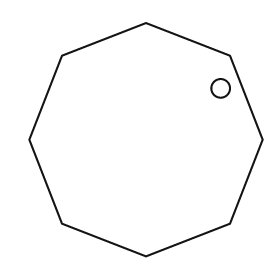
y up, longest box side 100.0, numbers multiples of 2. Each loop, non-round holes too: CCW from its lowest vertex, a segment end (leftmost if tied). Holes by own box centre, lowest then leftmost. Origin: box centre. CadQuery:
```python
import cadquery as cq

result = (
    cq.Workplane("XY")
    .moveTo(0.0, -50.0)
    .lineTo(36.0, -36.0)
    .lineTo(50.0, 0.0)
    .lineTo(36.0, 36.0)
    .lineTo(0.0, 50.0)
    .lineTo(-36.0, 36.0)
    .lineTo(-50.0, 0.0)
    .lineTo(-36.0, -36.0)
    .close()
    .moveTo(32.0, 22.0)
    .circle(4.0)
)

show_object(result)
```